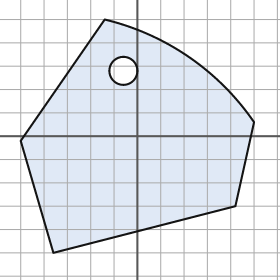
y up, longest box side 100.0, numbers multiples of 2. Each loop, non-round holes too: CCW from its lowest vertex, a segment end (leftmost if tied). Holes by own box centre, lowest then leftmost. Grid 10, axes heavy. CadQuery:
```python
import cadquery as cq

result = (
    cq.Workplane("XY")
    .moveTo(-36.0, -50.0)
    .lineTo(42.0, -30.0)
    .lineTo(50.0, 6.0)
    .threePointArc((22.0, 34.0), (-14.0, 50.0))
    .lineTo(-50.0, -2.0)
    .close()
    .moveTo(-6.0, 28.0)
    .circle(6.0)
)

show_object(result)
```